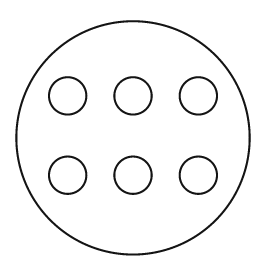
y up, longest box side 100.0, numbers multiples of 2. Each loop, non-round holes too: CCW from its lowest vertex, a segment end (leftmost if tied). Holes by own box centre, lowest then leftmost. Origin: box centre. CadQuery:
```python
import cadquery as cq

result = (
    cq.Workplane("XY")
    .moveTo(0.0, 0.0)
    .circle(50.0)
    .moveTo(-28.0, -16.0)
    .circle(8.0)
    .moveTo(0.0, -16.0)
    .circle(8.0)
    .moveTo(28.0, -16.0)
    .circle(8.0)
    .moveTo(-28.0, 18.0)
    .circle(8.0)
    .moveTo(0.0, 18.0)
    .circle(8.0)
    .moveTo(28.0, 18.0)
    .circle(8.0)
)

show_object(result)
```